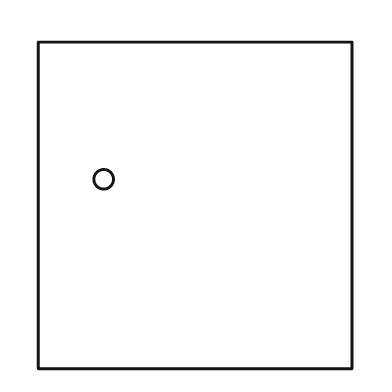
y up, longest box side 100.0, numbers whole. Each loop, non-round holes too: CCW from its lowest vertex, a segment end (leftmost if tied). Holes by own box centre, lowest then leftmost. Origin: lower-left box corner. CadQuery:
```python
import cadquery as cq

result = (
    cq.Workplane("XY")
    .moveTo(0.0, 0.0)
    .lineTo(96.0, 0.0)
    .lineTo(96.0, 100.0)
    .lineTo(0.0, 100.0)
    .close()
    .moveTo(20.0, 58.0)
    .circle(3.0)
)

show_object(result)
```